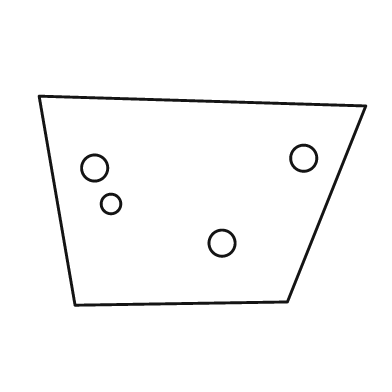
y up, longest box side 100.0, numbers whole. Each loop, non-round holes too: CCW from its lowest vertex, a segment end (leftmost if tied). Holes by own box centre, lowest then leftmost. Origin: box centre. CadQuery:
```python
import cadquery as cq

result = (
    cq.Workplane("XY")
    .moveTo(-39.0, -32.0)
    .lineTo(26.0, -31.0)
    .lineTo(50.0, 29.0)
    .lineTo(-50.0, 32.0)
    .close()
    .moveTo(6.0, -13.0)
    .circle(4.0)
    .moveTo(-28.0, -1.0)
    .circle(3.0)
    .moveTo(-33.0, 10.0)
    .circle(4.0)
    .moveTo(31.0, 13.0)
    .circle(4.0)
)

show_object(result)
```